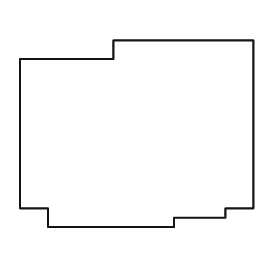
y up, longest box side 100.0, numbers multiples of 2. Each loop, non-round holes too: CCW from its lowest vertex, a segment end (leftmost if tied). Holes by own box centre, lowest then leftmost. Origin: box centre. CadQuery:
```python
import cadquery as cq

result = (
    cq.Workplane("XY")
    .moveTo(-38.0, -40.0)
    .lineTo(16.0, -40.0)
    .lineTo(16.0, -36.0)
    .lineTo(38.0, -36.0)
    .lineTo(38.0, -32.0)
    .lineTo(50.0, -32.0)
    .lineTo(50.0, 40.0)
    .lineTo(-10.0, 40.0)
    .lineTo(-10.0, 32.0)
    .lineTo(-50.0, 32.0)
    .lineTo(-50.0, -32.0)
    .lineTo(-38.0, -32.0)
    .close()
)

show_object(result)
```